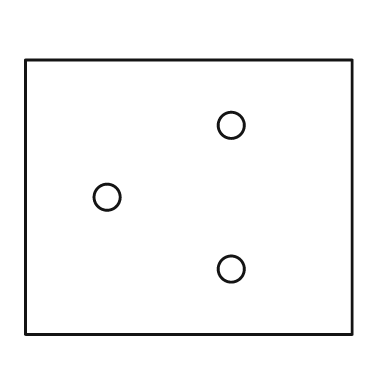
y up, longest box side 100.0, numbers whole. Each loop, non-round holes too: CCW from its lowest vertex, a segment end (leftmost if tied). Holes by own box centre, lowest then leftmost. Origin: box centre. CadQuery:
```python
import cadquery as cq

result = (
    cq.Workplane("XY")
    .moveTo(-50.0, -42.0)
    .lineTo(50.0, -42.0)
    .lineTo(50.0, 42.0)
    .lineTo(-50.0, 42.0)
    .close()
    .moveTo(13.0, -22.0)
    .circle(4.0)
    .moveTo(-25.0, 0.0)
    .circle(4.0)
    .moveTo(13.0, 22.0)
    .circle(4.0)
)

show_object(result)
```